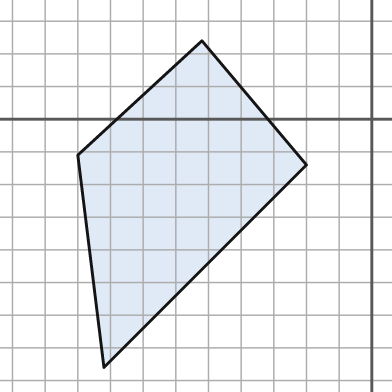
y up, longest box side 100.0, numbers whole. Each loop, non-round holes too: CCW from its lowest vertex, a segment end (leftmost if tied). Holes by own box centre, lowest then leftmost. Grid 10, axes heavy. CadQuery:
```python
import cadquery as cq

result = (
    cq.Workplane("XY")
    .moveTo(-82.0, -76.0)
    .lineTo(-20.0, -14.0)
    .lineTo(-52.0, 24.0)
    .lineTo(-90.0, -11.0)
    .close()
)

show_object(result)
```